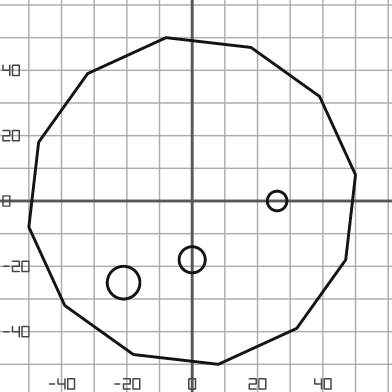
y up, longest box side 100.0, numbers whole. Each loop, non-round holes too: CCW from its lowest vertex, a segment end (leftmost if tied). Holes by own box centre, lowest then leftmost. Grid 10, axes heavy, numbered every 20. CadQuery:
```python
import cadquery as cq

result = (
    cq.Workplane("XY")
    .moveTo(8.0, -50.0)
    .lineTo(32.0, -39.0)
    .lineTo(47.0, -18.0)
    .lineTo(50.0, 8.0)
    .lineTo(39.0, 32.0)
    .lineTo(18.0, 47.0)
    .lineTo(-8.0, 50.0)
    .lineTo(-32.0, 39.0)
    .lineTo(-47.0, 18.0)
    .lineTo(-50.0, -8.0)
    .lineTo(-39.0, -32.0)
    .lineTo(-18.0, -47.0)
    .close()
    .moveTo(-21.0, -25.0)
    .circle(5.0)
    .moveTo(0.0, -18.0)
    .circle(4.0)
    .moveTo(26.0, 0.0)
    .circle(3.0)
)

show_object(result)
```